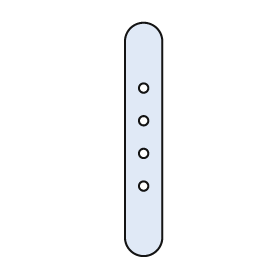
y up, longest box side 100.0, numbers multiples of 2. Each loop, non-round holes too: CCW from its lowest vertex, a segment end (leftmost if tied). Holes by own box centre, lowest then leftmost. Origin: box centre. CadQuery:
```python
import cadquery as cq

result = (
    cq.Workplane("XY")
    .moveTo(-8.0, -42.0)
    .threePointArc((0.0, -50.0), (8.0, -42.0))
    .lineTo(8.0, 42.0)
    .threePointArc((0.0, 50.0), (-8.0, 42.0))
    .close()
    .moveTo(0.0, -20.0)
    .circle(2.0)
    .moveTo(0.0, -6.0)
    .circle(2.0)
    .moveTo(0.0, 8.0)
    .circle(2.0)
    .moveTo(0.0, 22.0)
    .circle(2.0)
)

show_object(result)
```